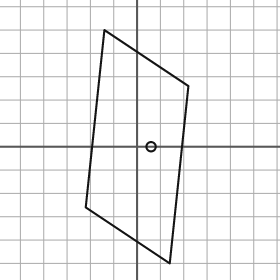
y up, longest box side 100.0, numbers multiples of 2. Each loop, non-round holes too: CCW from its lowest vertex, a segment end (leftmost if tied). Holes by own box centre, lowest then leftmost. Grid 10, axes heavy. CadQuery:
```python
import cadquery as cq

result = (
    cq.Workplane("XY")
    .moveTo(14.0, -50.0)
    .lineTo(22.0, 26.0)
    .lineTo(-14.0, 50.0)
    .lineTo(-22.0, -26.0)
    .close()
    .moveTo(6.0, 0.0)
    .circle(2.0)
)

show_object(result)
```